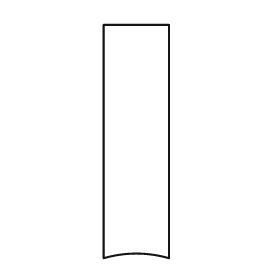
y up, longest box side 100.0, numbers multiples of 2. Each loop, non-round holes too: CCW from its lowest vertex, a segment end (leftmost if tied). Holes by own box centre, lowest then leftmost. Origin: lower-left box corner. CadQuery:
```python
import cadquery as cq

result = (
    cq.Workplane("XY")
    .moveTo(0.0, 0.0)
    .threePointArc((14.0, 2.0), (28.0, 0.0))
    .lineTo(28.0, 100.0)
    .lineTo(0.0, 100.0)
    .close()
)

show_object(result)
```